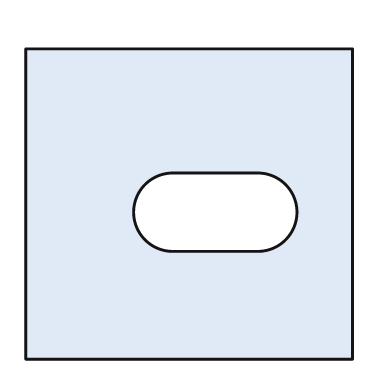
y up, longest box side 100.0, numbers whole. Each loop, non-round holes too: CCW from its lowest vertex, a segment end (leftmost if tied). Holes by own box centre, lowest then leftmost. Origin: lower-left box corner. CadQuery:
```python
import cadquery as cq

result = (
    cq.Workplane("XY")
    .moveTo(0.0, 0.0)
    .lineTo(100.0, 0.0)
    .lineTo(100.0, 95.0)
    .lineTo(0.0, 95.0)
    .close()
    .moveTo(45.0, 33.0)
    .lineTo(71.0, 33.0)
    .threePointArc((83.0, 45.0), (71.0, 57.0))
    .lineTo(45.0, 57.0)
    .threePointArc((33.0, 45.0), (45.0, 33.0))
    .close()
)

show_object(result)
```